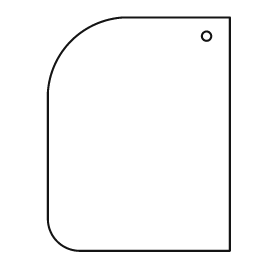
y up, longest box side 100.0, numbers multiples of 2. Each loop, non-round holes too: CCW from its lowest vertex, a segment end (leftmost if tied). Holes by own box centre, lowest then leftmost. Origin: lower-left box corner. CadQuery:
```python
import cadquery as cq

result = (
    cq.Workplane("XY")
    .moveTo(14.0, 0.0)
    .lineTo(78.0, 0.0)
    .lineTo(78.0, 100.0)
    .lineTo(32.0, 100.0)
    .threePointArc((10.0, 90.0), (0.0, 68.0))
    .lineTo(0.0, 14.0)
    .threePointArc((4.0, 4.0), (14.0, 0.0))
    .close()
    .moveTo(68.0, 92.0)
    .circle(2.0)
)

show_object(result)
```